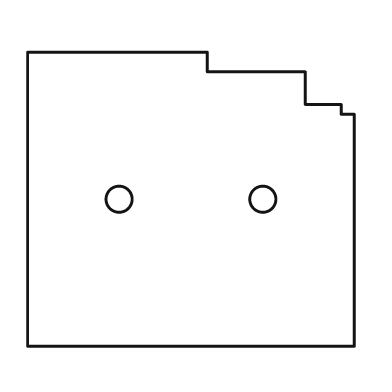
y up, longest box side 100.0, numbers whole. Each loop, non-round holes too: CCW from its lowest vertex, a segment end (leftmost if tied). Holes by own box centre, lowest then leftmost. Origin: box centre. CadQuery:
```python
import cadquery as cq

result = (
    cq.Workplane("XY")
    .moveTo(-50.0, -45.0)
    .lineTo(50.0, -45.0)
    .lineTo(50.0, 26.0)
    .lineTo(46.0, 26.0)
    .lineTo(46.0, 29.0)
    .lineTo(35.0, 29.0)
    .lineTo(35.0, 39.0)
    .lineTo(5.0, 39.0)
    .lineTo(5.0, 45.0)
    .lineTo(-50.0, 45.0)
    .close()
    .moveTo(-22.0, 0.0)
    .circle(4.0)
    .moveTo(22.0, 0.0)
    .circle(4.0)
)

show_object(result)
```